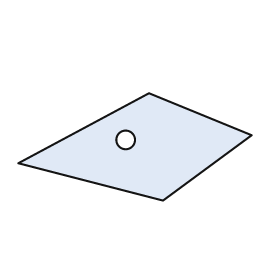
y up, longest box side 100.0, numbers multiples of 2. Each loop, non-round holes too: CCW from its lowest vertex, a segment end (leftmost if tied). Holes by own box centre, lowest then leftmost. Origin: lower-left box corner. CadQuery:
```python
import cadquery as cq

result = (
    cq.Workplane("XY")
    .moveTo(62.0, 0.0)
    .lineTo(100.0, 28.0)
    .lineTo(56.0, 46.0)
    .lineTo(0.0, 16.0)
    .close()
    .moveTo(46.0, 26.0)
    .circle(4.0)
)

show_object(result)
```